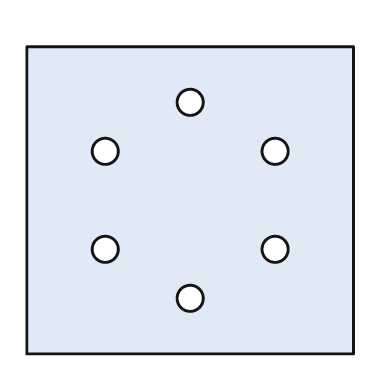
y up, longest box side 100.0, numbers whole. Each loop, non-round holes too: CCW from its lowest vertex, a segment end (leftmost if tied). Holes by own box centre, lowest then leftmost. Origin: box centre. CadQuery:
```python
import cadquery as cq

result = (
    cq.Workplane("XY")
    .moveTo(-50.0, -47.0)
    .lineTo(50.0, -47.0)
    .lineTo(50.0, 47.0)
    .lineTo(-50.0, 47.0)
    .close()
    .moveTo(0.0, -30.0)
    .circle(4.0)
    .moveTo(-26.0, -15.0)
    .circle(4.0)
    .moveTo(26.0, -15.0)
    .circle(4.0)
    .moveTo(-26.0, 15.0)
    .circle(4.0)
    .moveTo(26.0, 15.0)
    .circle(4.0)
    .moveTo(0.0, 30.0)
    .circle(4.0)
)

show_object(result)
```